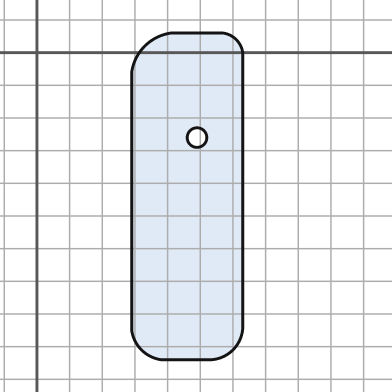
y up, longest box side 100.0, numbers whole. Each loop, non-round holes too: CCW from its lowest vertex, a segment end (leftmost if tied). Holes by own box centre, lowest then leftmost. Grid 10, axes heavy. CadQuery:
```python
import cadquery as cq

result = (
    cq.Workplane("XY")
    .moveTo(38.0, -94.0)
    .lineTo(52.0, -94.0)
    .threePointArc((60.0, -91.0), (63.0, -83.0))
    .lineTo(63.0, 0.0)
    .threePointArc((61.0, 4.0), (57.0, 6.0))
    .lineTo(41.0, 6.0)
    .threePointArc((33.0, 2.0), (29.0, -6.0))
    .lineTo(29.0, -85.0)
    .threePointArc((32.0, -91.0), (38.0, -94.0))
    .close()
    .moveTo(49.0, -26.0)
    .circle(3.0)
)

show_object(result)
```